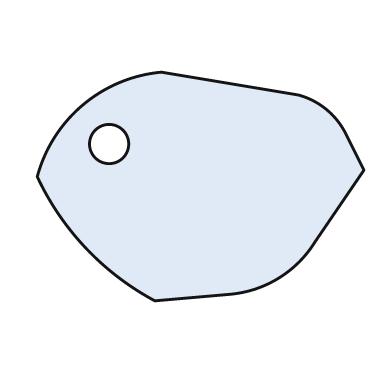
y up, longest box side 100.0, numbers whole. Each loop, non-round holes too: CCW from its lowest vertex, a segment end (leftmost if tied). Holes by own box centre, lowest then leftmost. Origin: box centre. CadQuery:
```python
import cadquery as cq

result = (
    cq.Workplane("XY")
    .moveTo(-14.0, -35.0)
    .lineTo(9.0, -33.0)
    .threePointArc((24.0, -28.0), (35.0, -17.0))
    .lineTo(50.0, 5.0)
    .lineTo(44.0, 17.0)
    .threePointArc((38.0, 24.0), (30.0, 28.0))
    .lineTo(-12.0, 35.0)
    .threePointArc((-36.0, 25.0), (-50.0, 3.0))
    .threePointArc((-35.0, -19.0), (-14.0, -35.0))
    .close()
    .moveTo(-28.0, 13.0)
    .circle(6.0)
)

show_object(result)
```